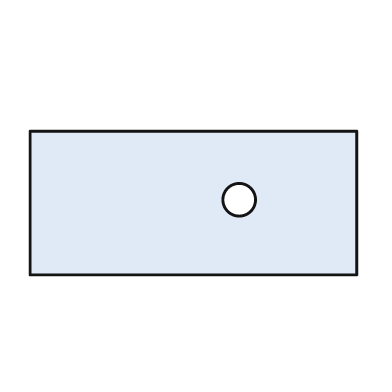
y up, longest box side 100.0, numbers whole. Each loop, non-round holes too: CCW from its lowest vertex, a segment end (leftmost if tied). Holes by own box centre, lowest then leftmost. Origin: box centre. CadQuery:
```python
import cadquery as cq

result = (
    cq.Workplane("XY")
    .moveTo(-50.0, -22.0)
    .lineTo(50.0, -22.0)
    .lineTo(50.0, 22.0)
    .lineTo(-50.0, 22.0)
    .close()
    .moveTo(14.0, 1.0)
    .circle(5.0)
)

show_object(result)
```